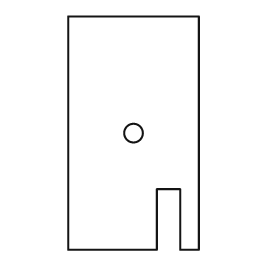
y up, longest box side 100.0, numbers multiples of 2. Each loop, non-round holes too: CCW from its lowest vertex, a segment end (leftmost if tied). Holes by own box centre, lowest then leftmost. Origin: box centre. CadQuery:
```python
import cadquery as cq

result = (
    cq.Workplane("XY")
    .moveTo(-28.0, -50.0)
    .lineTo(10.0, -50.0)
    .lineTo(10.0, -24.0)
    .lineTo(20.0, -24.0)
    .lineTo(20.0, -50.0)
    .lineTo(28.0, -50.0)
    .lineTo(28.0, 50.0)
    .lineTo(-28.0, 50.0)
    .close()
    .moveTo(0.0, 0.0)
    .circle(4.0)
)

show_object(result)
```